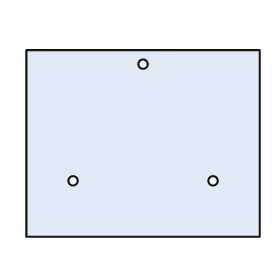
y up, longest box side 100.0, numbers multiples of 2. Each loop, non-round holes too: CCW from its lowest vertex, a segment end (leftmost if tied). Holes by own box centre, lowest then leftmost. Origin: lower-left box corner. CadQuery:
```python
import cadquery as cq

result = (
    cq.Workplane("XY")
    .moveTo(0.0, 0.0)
    .lineTo(100.0, 0.0)
    .lineTo(100.0, 80.0)
    .lineTo(0.0, 80.0)
    .close()
    .moveTo(20.0, 24.0)
    .circle(2.0)
    .moveTo(80.0, 24.0)
    .circle(2.0)
    .moveTo(50.0, 74.0)
    .circle(2.0)
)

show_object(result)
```